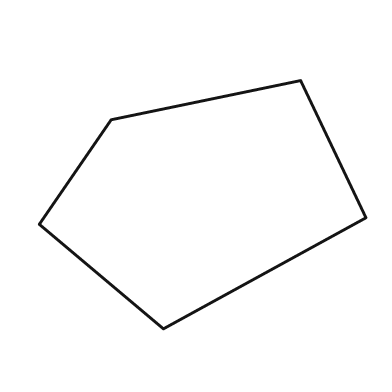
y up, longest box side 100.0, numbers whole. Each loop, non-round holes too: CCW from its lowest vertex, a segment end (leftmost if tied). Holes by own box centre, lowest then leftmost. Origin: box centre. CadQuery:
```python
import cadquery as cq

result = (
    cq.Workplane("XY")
    .moveTo(-12.0, -38.0)
    .lineTo(50.0, -4.0)
    .lineTo(30.0, 38.0)
    .lineTo(-28.0, 26.0)
    .lineTo(-50.0, -6.0)
    .close()
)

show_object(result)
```